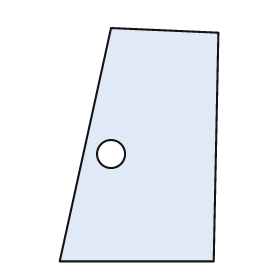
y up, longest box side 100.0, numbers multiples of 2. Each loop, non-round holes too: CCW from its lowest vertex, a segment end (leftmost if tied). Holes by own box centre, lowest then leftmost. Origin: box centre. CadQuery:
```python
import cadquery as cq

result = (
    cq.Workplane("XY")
    .moveTo(-34.0, -50.0)
    .lineTo(32.0, -50.0)
    .lineTo(34.0, 48.0)
    .lineTo(-12.0, 50.0)
    .close()
    .moveTo(-12.0, -4.0)
    .circle(6.0)
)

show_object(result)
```